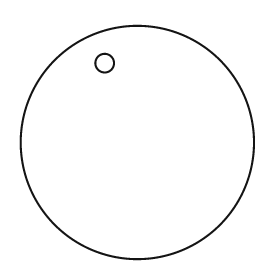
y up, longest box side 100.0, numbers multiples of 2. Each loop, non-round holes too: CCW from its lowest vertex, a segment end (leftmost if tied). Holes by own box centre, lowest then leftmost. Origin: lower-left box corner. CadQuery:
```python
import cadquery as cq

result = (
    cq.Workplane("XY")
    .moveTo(50.0, 50.0)
    .circle(50.0)
    .moveTo(36.0, 84.0)
    .circle(4.0)
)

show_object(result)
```